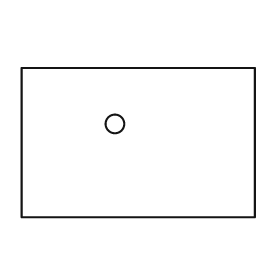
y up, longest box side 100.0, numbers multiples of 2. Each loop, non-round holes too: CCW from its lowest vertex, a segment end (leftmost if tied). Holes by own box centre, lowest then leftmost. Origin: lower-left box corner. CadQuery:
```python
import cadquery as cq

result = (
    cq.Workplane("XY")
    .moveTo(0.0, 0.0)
    .lineTo(100.0, 0.0)
    .lineTo(100.0, 64.0)
    .lineTo(0.0, 64.0)
    .close()
    .moveTo(40.0, 40.0)
    .circle(4.0)
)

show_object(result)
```